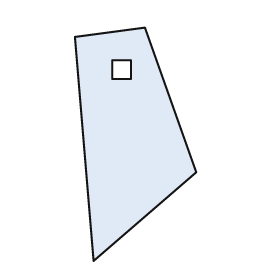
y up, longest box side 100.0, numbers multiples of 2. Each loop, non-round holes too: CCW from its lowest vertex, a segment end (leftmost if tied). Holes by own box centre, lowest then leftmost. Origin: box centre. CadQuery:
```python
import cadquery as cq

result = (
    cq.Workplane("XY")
    .moveTo(-18.0, -50.0)
    .lineTo(26.0, -12.0)
    .lineTo(4.0, 50.0)
    .lineTo(-26.0, 46.0)
    .close()
    .moveTo(-10.0, 28.0)
    .lineTo(-2.0, 28.0)
    .lineTo(-2.0, 36.0)
    .lineTo(-10.0, 36.0)
    .close()
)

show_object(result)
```